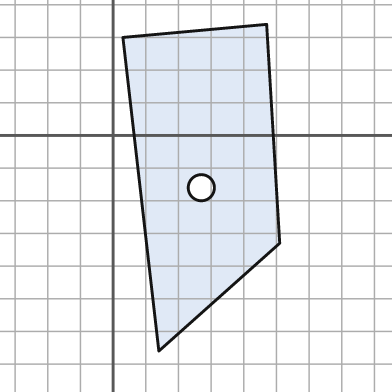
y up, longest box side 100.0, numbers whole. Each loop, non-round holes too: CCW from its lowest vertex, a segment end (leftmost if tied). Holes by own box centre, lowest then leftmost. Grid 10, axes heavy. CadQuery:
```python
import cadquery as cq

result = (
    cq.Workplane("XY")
    .moveTo(14.0, -66.0)
    .lineTo(51.0, -33.0)
    .lineTo(47.0, 34.0)
    .lineTo(3.0, 30.0)
    .close()
    .moveTo(27.0, -16.0)
    .circle(4.0)
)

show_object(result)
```